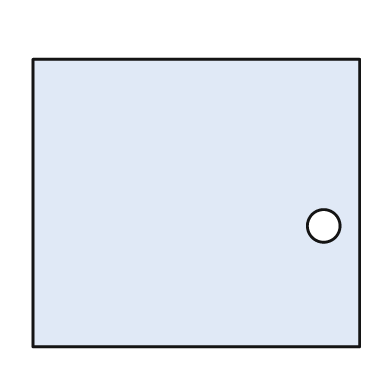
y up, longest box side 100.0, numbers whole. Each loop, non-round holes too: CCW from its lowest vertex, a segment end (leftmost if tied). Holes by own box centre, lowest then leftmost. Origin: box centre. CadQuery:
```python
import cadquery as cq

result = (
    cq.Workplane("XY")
    .moveTo(-50.0, -44.0)
    .lineTo(50.0, -44.0)
    .lineTo(50.0, 44.0)
    .lineTo(-50.0, 44.0)
    .close()
    .moveTo(39.0, -7.0)
    .circle(5.0)
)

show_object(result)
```